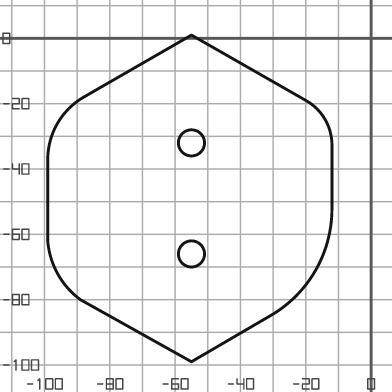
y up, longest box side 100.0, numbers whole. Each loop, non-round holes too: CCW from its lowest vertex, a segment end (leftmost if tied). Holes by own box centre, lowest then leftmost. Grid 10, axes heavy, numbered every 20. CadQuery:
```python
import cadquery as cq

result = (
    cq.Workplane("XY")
    .moveTo(-55.0, -99.0)
    .lineTo(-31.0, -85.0)
    .threePointArc((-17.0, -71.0), (-12.0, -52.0))
    .lineTo(-12.0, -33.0)
    .threePointArc((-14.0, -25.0), (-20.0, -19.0))
    .lineTo(-55.0, 1.0)
    .lineTo(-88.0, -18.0)
    .threePointArc((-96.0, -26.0), (-99.0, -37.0))
    .lineTo(-99.0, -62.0)
    .threePointArc((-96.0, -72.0), (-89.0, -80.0))
    .close()
    .moveTo(-55.0, -66.0)
    .circle(4.0)
    .moveTo(-55.0, -32.0)
    .circle(4.0)
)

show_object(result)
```